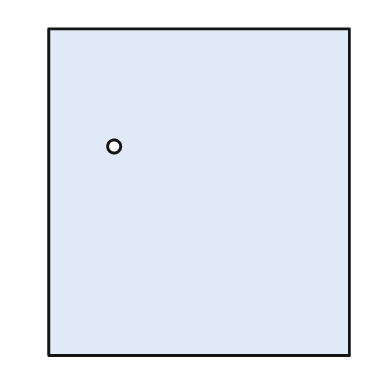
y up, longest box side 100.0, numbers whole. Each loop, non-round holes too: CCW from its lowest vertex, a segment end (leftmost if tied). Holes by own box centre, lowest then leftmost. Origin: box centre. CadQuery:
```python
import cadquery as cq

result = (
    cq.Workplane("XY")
    .moveTo(-46.0, -50.0)
    .lineTo(46.0, -50.0)
    .lineTo(46.0, 50.0)
    .lineTo(-46.0, 50.0)
    .close()
    .moveTo(-26.0, 14.0)
    .circle(2.0)
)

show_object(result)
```